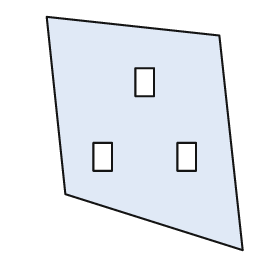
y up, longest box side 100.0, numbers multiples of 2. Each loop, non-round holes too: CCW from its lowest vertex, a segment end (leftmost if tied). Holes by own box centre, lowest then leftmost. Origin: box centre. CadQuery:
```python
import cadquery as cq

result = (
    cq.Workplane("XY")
    .moveTo(42.0, -50.0)
    .lineTo(32.0, 42.0)
    .lineTo(-42.0, 50.0)
    .lineTo(-34.0, -26.0)
    .close()
    .moveTo(-22.0, -16.0)
    .lineTo(-14.0, -16.0)
    .lineTo(-14.0, -4.0)
    .lineTo(-22.0, -4.0)
    .close()
    .moveTo(14.0, -16.0)
    .lineTo(22.0, -16.0)
    .lineTo(22.0, -4.0)
    .lineTo(14.0, -4.0)
    .close()
    .moveTo(-4.0, 16.0)
    .lineTo(4.0, 16.0)
    .lineTo(4.0, 28.0)
    .lineTo(-4.0, 28.0)
    .close()
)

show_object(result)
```